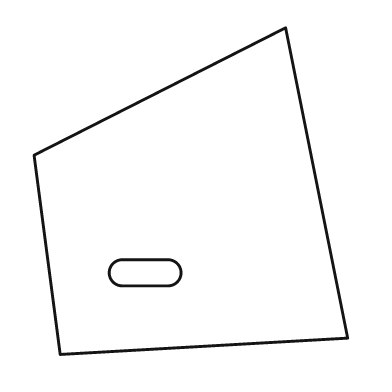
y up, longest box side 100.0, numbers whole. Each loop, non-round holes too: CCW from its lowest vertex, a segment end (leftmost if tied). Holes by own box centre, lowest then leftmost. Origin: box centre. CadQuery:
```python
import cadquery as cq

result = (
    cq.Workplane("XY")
    .moveTo(-40.0, -50.0)
    .lineTo(48.0, -45.0)
    .lineTo(29.0, 50.0)
    .lineTo(-48.0, 11.0)
    .close()
    .moveTo(-21.0, -29.0)
    .lineTo(-7.0, -29.0)
    .threePointArc((-3.0, -25.0), (-7.0, -21.0))
    .lineTo(-21.0, -21.0)
    .threePointArc((-25.0, -25.0), (-21.0, -29.0))
    .close()
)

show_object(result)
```